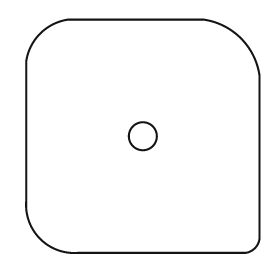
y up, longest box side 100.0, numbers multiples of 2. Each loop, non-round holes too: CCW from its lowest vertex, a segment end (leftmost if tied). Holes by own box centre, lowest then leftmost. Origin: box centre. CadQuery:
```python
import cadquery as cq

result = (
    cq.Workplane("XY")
    .moveTo(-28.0, -50.0)
    .lineTo(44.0, -50.0)
    .threePointArc((48.0, -48.0), (50.0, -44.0))
    .lineTo(50.0, 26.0)
    .threePointArc((42.0, 42.0), (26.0, 50.0))
    .lineTo(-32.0, 50.0)
    .threePointArc((-44.0, 44.0), (-50.0, 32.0))
    .lineTo(-50.0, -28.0)
    .threePointArc((-44.0, -44.0), (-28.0, -50.0))
    .close()
    .moveTo(0.0, 0.0)
    .circle(6.0)
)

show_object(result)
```